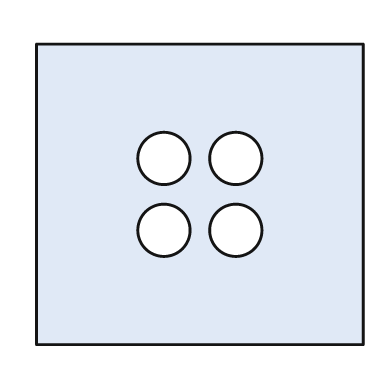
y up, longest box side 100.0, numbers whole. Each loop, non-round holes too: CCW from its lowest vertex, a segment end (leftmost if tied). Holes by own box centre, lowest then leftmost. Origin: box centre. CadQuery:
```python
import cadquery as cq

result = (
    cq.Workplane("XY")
    .moveTo(-50.0, -46.0)
    .lineTo(50.0, -46.0)
    .lineTo(50.0, 46.0)
    .lineTo(-50.0, 46.0)
    .close()
    .moveTo(-11.0, -11.0)
    .circle(8.0)
    .moveTo(11.0, -11.0)
    .circle(8.0)
    .moveTo(-11.0, 11.0)
    .circle(8.0)
    .moveTo(11.0, 11.0)
    .circle(8.0)
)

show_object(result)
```